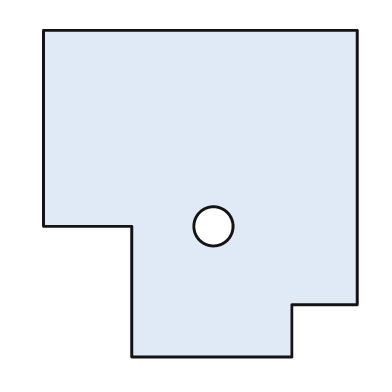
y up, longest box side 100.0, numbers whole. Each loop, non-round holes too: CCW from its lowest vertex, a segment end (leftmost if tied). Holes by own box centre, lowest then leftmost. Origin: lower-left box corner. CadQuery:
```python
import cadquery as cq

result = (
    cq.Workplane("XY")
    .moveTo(27.0, 0.0)
    .lineTo(76.0, 0.0)
    .lineTo(76.0, 16.0)
    .lineTo(96.0, 16.0)
    .lineTo(96.0, 100.0)
    .lineTo(0.0, 100.0)
    .lineTo(0.0, 40.0)
    .lineTo(27.0, 40.0)
    .close()
    .moveTo(52.0, 40.0)
    .circle(6.0)
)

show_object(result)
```